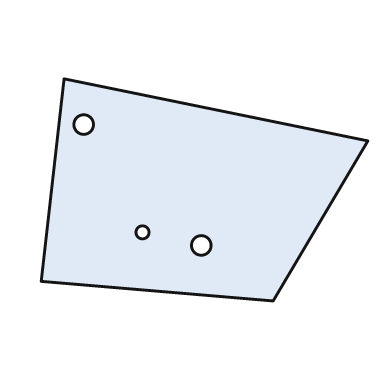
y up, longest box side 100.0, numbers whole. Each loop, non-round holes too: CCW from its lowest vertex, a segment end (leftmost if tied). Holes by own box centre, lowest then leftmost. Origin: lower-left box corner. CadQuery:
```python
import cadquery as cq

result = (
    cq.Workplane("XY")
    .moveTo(71.0, 0.0)
    .lineTo(100.0, 49.0)
    .lineTo(7.0, 68.0)
    .lineTo(0.0, 6.0)
    .close()
    .moveTo(49.0, 17.0)
    .circle(3.0)
    .moveTo(31.0, 21.0)
    .circle(2.0)
    .moveTo(13.0, 54.0)
    .circle(3.0)
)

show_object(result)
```